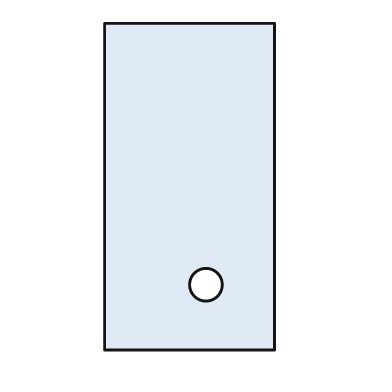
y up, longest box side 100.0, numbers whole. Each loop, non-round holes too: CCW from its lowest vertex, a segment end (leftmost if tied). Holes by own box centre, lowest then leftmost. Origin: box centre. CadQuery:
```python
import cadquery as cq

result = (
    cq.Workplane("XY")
    .moveTo(-26.0, -50.0)
    .lineTo(26.0, -50.0)
    .lineTo(26.0, 50.0)
    .lineTo(-26.0, 50.0)
    .close()
    .moveTo(5.0, -30.0)
    .circle(5.0)
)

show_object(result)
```